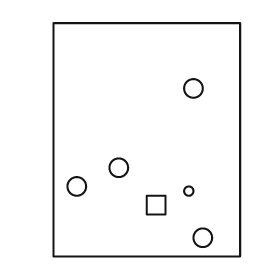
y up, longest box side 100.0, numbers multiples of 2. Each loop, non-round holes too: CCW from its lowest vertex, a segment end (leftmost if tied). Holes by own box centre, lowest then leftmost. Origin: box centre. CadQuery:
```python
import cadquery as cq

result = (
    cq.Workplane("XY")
    .moveTo(-40.0, -50.0)
    .lineTo(40.0, -50.0)
    .lineTo(40.0, 50.0)
    .lineTo(-40.0, 50.0)
    .close()
    .moveTo(24.0, -42.0)
    .circle(4.0)
    .moveTo(0.0, -32.0)
    .lineTo(8.0, -32.0)
    .lineTo(8.0, -24.0)
    .lineTo(0.0, -24.0)
    .close()
    .moveTo(18.0, -22.0)
    .circle(2.0)
    .moveTo(-30.0, -20.0)
    .circle(4.0)
    .moveTo(-12.0, -12.0)
    .circle(4.0)
    .moveTo(20.0, 22.0)
    .circle(4.0)
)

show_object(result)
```